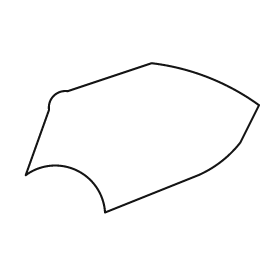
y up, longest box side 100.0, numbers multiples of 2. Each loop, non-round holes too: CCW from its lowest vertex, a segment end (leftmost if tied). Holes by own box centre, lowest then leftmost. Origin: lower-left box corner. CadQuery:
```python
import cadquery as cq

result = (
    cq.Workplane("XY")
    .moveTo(34.0, 0.0)
    .lineTo(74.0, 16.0)
    .threePointArc((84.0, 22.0), (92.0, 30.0))
    .lineTo(100.0, 46.0)
    .threePointArc((78.0, 58.0), (54.0, 64.0))
    .lineTo(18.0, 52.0)
    .threePointArc((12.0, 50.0), (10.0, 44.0))
    .lineTo(0.0, 16.0)
    .threePointArc((22.0, 18.0), (34.0, 0.0))
    .close()
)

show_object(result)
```